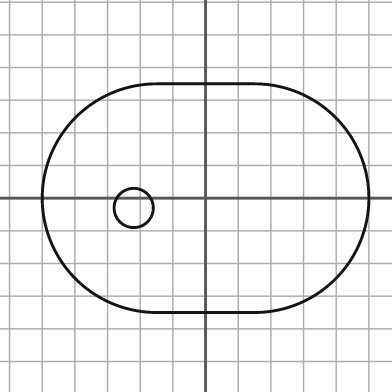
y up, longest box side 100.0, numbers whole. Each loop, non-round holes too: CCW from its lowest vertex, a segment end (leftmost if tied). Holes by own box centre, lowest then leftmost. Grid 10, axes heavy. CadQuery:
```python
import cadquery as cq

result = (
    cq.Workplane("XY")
    .moveTo(-15.0, -35.0)
    .lineTo(15.0, -35.0)
    .threePointArc((50.0, 0.0), (15.0, 35.0))
    .lineTo(-15.0, 35.0)
    .threePointArc((-50.0, 0.0), (-15.0, -35.0))
    .close()
    .moveTo(-22.0, -3.0)
    .circle(6.0)
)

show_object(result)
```